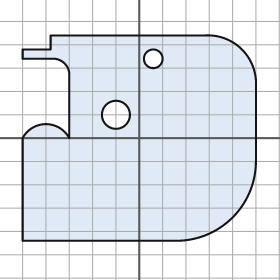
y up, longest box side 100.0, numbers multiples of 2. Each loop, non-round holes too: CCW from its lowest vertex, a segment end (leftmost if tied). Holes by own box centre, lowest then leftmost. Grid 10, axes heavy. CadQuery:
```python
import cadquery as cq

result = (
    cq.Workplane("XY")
    .moveTo(-50.0, -44.0)
    .lineTo(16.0, -44.0)
    .threePointArc((40.0, -34.0), (50.0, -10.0))
    .lineTo(50.0, 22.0)
    .threePointArc((44.0, 38.0), (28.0, 44.0))
    .lineTo(-38.0, 44.0)
    .lineTo(-38.0, 38.0)
    .lineTo(-50.0, 38.0)
    .lineTo(-50.0, 34.0)
    .lineTo(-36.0, 34.0)
    .threePointArc((-32.0, 32.0), (-30.0, 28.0))
    .lineTo(-30.0, 0.0)
    .threePointArc((-40.0, 6.0), (-50.0, 0.0))
    .close()
    .moveTo(-10.0, 10.0)
    .circle(6.0)
    .moveTo(6.0, 34.0)
    .circle(4.0)
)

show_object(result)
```